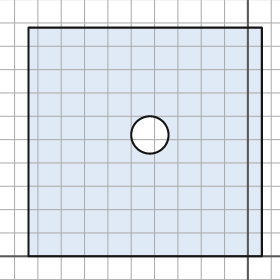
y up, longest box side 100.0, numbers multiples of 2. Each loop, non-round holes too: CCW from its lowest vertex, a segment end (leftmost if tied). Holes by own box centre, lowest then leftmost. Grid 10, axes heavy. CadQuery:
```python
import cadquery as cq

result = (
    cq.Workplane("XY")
    .moveTo(-94.0, 0.0)
    .lineTo(6.0, 0.0)
    .lineTo(6.0, 98.0)
    .lineTo(-94.0, 98.0)
    .close()
    .moveTo(-42.0, 52.0)
    .circle(8.0)
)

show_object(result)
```